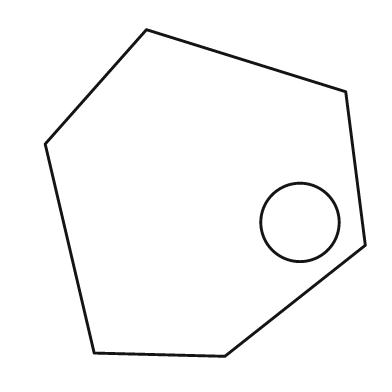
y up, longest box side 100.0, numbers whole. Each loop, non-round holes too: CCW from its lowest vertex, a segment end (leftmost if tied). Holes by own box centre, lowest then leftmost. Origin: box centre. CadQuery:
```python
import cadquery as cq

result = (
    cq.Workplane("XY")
    .moveTo(6.0, -50.0)
    .lineTo(49.0, -16.0)
    .lineTo(43.0, 31.0)
    .lineTo(-18.0, 50.0)
    .lineTo(-49.0, 15.0)
    .lineTo(-34.0, -49.0)
    .close()
    .moveTo(29.0, -9.0)
    .circle(12.0)
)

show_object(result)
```